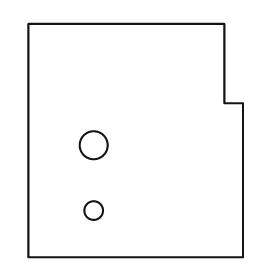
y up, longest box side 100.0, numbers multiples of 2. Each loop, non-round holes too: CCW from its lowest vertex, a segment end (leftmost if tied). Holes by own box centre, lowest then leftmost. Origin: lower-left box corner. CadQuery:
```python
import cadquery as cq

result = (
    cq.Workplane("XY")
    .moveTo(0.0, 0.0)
    .lineTo(92.0, 0.0)
    .lineTo(92.0, 66.0)
    .lineTo(84.0, 66.0)
    .lineTo(84.0, 100.0)
    .lineTo(0.0, 100.0)
    .close()
    .moveTo(28.0, 20.0)
    .circle(4.0)
    .moveTo(28.0, 48.0)
    .circle(6.0)
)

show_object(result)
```